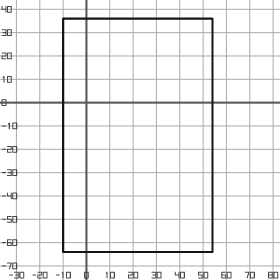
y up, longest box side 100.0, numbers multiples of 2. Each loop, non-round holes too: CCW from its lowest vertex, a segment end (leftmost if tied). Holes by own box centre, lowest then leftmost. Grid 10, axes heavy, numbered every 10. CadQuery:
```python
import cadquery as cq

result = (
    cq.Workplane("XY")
    .moveTo(-10.0, -64.0)
    .lineTo(54.0, -64.0)
    .lineTo(54.0, 36.0)
    .lineTo(-10.0, 36.0)
    .close()
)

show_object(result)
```